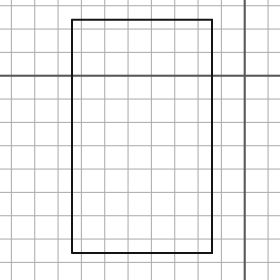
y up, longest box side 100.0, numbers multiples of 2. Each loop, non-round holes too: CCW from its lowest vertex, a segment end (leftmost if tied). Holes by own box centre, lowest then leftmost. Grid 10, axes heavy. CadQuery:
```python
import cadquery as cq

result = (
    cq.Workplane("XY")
    .moveTo(-74.0, -76.0)
    .lineTo(-14.0, -76.0)
    .lineTo(-14.0, 24.0)
    .lineTo(-74.0, 24.0)
    .close()
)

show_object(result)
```